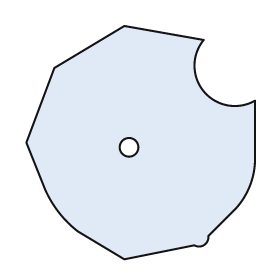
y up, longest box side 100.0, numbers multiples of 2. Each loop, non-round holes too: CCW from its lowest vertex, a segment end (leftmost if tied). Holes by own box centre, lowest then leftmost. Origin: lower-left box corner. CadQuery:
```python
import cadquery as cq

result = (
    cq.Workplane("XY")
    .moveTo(42.0, 0.0)
    .lineTo(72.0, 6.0)
    .threePointArc((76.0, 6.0), (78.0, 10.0))
    .lineTo(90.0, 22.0)
    .threePointArc((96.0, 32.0), (98.0, 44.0))
    .lineTo(98.0, 68.0)
    .threePointArc((76.0, 72.0), (76.0, 94.0))
    .lineTo(42.0, 100.0)
    .lineTo(12.0, 82.0)
    .lineTo(0.0, 50.0)
    .lineTo(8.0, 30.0)
    .threePointArc((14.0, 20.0), (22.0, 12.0))
    .close()
    .moveTo(44.0, 48.0)
    .circle(4.0)
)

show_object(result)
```